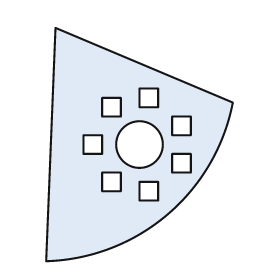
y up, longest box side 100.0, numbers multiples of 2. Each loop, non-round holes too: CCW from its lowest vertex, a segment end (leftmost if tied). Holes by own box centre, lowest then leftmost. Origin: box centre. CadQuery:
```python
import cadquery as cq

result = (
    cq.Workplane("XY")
    .moveTo(-40.0, -50.0)
    .threePointArc((12.0, -30.0), (40.0, 18.0))
    .lineTo(-36.0, 50.0)
    .close()
    .moveTo(0.0, -24.0)
    .lineTo(8.0, -24.0)
    .lineTo(8.0, -16.0)
    .lineTo(0.0, -16.0)
    .close()
    .moveTo(-16.0, -20.0)
    .lineTo(-8.0, -20.0)
    .lineTo(-8.0, -12.0)
    .lineTo(-16.0, -12.0)
    .close()
    .moveTo(14.0, -12.0)
    .lineTo(22.0, -12.0)
    .lineTo(22.0, -4.0)
    .lineTo(14.0, -4.0)
    .close()
    .moveTo(-24.0, -4.0)
    .lineTo(-16.0, -4.0)
    .lineTo(-16.0, 4.0)
    .lineTo(-24.0, 4.0)
    .close()
    .moveTo(0.0, 0.0)
    .circle(10.0)
    .moveTo(14.0, 4.0)
    .lineTo(22.0, 4.0)
    .lineTo(22.0, 12.0)
    .lineTo(14.0, 12.0)
    .close()
    .moveTo(-16.0, 12.0)
    .lineTo(-8.0, 12.0)
    .lineTo(-8.0, 20.0)
    .lineTo(-16.0, 20.0)
    .close()
    .moveTo(0.0, 16.0)
    .lineTo(8.0, 16.0)
    .lineTo(8.0, 24.0)
    .lineTo(0.0, 24.0)
    .close()
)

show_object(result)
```